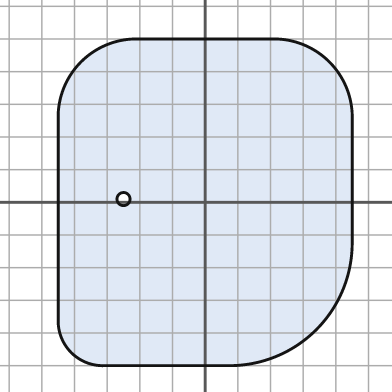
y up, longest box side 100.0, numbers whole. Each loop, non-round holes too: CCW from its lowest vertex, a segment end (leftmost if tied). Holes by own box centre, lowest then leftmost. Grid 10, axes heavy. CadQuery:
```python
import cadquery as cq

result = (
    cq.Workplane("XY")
    .moveTo(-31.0, -50.0)
    .lineTo(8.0, -50.0)
    .threePointArc((34.0, -39.0), (45.0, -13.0))
    .lineTo(45.0, 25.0)
    .threePointArc((38.0, 43.0), (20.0, 50.0))
    .lineTo(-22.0, 50.0)
    .threePointArc((-38.0, 43.0), (-45.0, 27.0))
    .lineTo(-45.0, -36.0)
    .threePointArc((-41.0, -46.0), (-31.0, -50.0))
    .close()
    .moveTo(-25.0, 1.0)
    .circle(2.0)
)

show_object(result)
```